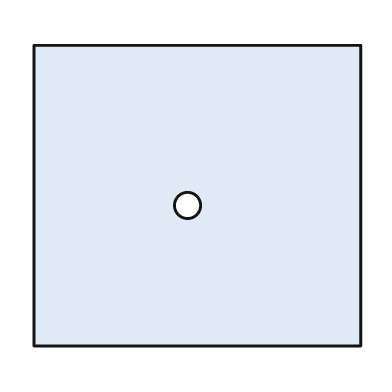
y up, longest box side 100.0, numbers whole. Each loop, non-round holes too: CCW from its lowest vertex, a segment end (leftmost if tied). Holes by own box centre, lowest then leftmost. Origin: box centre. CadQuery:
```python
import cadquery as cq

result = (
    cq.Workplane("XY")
    .moveTo(-50.0, -46.0)
    .lineTo(50.0, -46.0)
    .lineTo(50.0, 46.0)
    .lineTo(-50.0, 46.0)
    .close()
    .moveTo(-3.0, -3.0)
    .circle(4.0)
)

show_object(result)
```